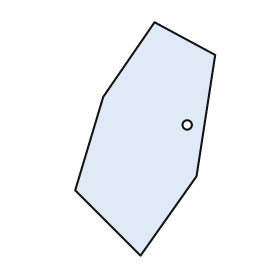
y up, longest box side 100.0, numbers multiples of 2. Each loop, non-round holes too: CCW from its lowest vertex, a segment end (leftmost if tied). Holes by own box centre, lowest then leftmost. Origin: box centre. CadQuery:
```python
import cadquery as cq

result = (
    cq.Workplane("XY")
    .moveTo(-2.0, -50.0)
    .lineTo(22.0, -16.0)
    .lineTo(30.0, 36.0)
    .lineTo(4.0, 50.0)
    .lineTo(-18.0, 18.0)
    .lineTo(-30.0, -22.0)
    .close()
    .moveTo(18.0, 6.0)
    .circle(2.0)
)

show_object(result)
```